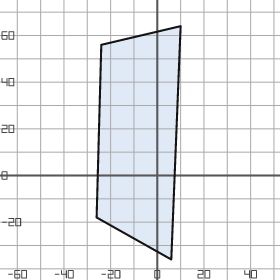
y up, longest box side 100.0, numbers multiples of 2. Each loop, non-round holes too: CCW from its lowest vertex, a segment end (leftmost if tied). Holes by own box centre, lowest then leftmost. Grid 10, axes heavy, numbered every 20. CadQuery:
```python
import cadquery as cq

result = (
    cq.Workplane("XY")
    .moveTo(6.0, -36.0)
    .lineTo(10.0, 64.0)
    .lineTo(-24.0, 56.0)
    .lineTo(-26.0, -18.0)
    .close()
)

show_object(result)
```